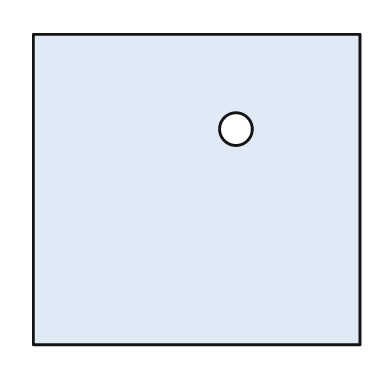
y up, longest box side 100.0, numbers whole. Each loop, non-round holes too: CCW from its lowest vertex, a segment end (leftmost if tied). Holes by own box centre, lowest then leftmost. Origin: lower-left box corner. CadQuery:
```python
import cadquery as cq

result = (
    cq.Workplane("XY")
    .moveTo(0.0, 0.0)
    .lineTo(100.0, 0.0)
    .lineTo(100.0, 95.0)
    .lineTo(0.0, 95.0)
    .close()
    .moveTo(62.0, 66.0)
    .circle(5.0)
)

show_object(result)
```